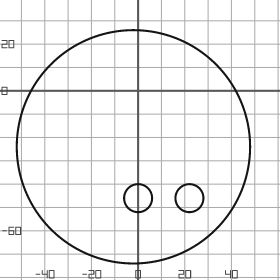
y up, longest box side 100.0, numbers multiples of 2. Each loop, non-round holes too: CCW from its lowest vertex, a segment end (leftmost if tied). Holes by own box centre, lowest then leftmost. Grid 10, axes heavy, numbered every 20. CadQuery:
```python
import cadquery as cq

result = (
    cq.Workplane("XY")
    .moveTo(-2.0, -24.0)
    .circle(50.0)
    .moveTo(0.0, -46.0)
    .circle(6.0)
    .moveTo(22.0, -46.0)
    .circle(6.0)
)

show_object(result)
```